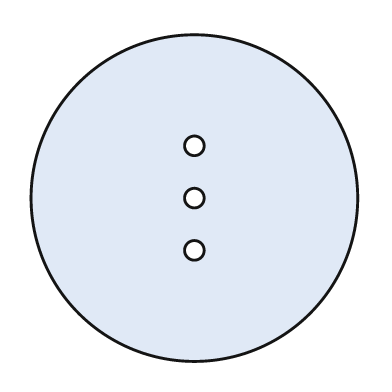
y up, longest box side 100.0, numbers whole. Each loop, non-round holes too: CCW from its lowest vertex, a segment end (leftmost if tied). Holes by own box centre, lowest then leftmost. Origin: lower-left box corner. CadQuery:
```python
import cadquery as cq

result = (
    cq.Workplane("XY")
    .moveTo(50.0, 50.0)
    .circle(50.0)
    .moveTo(50.0, 34.0)
    .circle(3.0)
    .moveTo(50.0, 50.0)
    .circle(3.0)
    .moveTo(50.0, 66.0)
    .circle(3.0)
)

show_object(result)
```